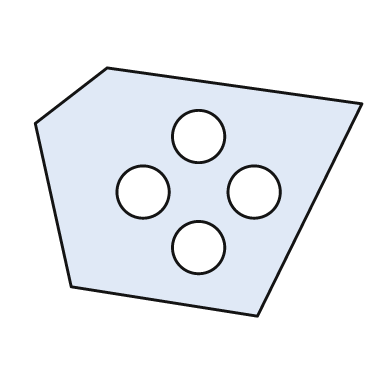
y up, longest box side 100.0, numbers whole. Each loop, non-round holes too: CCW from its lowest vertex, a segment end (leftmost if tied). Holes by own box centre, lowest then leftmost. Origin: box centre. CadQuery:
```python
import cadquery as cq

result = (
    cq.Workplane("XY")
    .moveTo(18.0, -38.0)
    .lineTo(50.0, 27.0)
    .lineTo(-28.0, 38.0)
    .lineTo(-50.0, 21.0)
    .lineTo(-39.0, -29.0)
    .close()
    .moveTo(0.0, -17.0)
    .circle(8.0)
    .moveTo(-17.0, 0.0)
    .circle(8.0)
    .moveTo(17.0, 0.0)
    .circle(8.0)
    .moveTo(0.0, 17.0)
    .circle(8.0)
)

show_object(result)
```